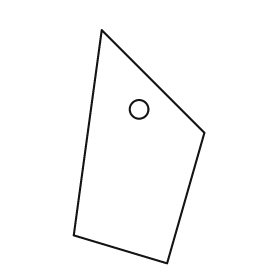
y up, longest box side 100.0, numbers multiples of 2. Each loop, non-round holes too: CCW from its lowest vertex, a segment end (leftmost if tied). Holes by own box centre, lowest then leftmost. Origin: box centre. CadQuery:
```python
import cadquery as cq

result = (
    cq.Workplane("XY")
    .moveTo(12.0, -50.0)
    .lineTo(28.0, 6.0)
    .lineTo(-16.0, 50.0)
    .lineTo(-28.0, -38.0)
    .close()
    .moveTo(0.0, 16.0)
    .circle(4.0)
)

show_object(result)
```